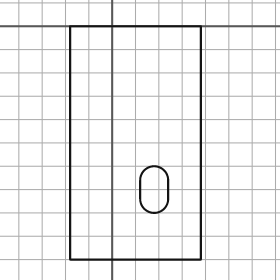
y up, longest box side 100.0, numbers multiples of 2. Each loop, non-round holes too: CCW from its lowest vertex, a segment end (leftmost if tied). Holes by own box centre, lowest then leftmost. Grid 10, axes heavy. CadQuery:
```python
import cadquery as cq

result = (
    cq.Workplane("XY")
    .moveTo(-18.0, -100.0)
    .lineTo(38.0, -100.0)
    .lineTo(38.0, 0.0)
    .lineTo(-18.0, 0.0)
    .close()
    .moveTo(12.0, -74.0)
    .threePointArc((18.0, -80.0), (24.0, -74.0))
    .lineTo(24.0, -66.0)
    .threePointArc((18.0, -60.0), (12.0, -66.0))
    .close()
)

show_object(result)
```